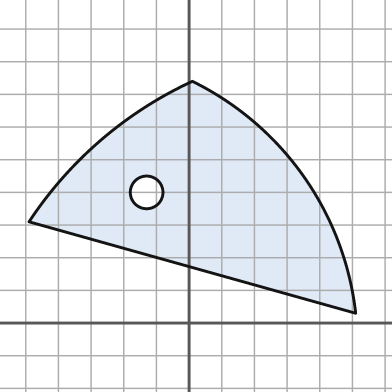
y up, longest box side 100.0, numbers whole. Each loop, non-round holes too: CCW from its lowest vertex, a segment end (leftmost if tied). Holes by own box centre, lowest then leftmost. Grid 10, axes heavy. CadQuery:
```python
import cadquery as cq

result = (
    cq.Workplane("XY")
    .moveTo(51.0, 3.0)
    .threePointArc((35.0, 45.0), (1.0, 74.0))
    .threePointArc((-27.0, 56.0), (-49.0, 31.0))
    .close()
    .moveTo(-13.0, 40.0)
    .circle(5.0)
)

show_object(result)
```